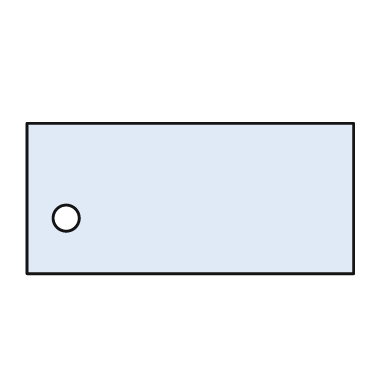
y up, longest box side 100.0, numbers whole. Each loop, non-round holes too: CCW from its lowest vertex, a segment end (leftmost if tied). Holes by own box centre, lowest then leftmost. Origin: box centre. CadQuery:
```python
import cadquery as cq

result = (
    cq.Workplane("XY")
    .moveTo(-50.0, -23.0)
    .lineTo(50.0, -23.0)
    .lineTo(50.0, 23.0)
    .lineTo(-50.0, 23.0)
    .close()
    .moveTo(-38.0, -6.0)
    .circle(4.0)
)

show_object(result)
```